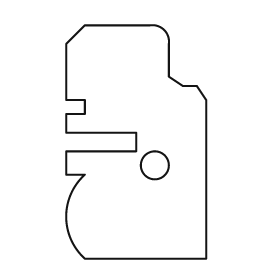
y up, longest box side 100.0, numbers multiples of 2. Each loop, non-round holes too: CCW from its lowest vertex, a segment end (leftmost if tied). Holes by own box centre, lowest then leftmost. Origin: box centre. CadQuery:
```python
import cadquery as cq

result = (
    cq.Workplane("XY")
    .moveTo(-22.0, -50.0)
    .lineTo(30.0, -50.0)
    .lineTo(30.0, 18.0)
    .lineTo(26.0, 24.0)
    .lineTo(20.0, 24.0)
    .lineTo(14.0, 28.0)
    .lineTo(14.0, 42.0)
    .threePointArc((12.0, 48.0), (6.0, 50.0))
    .lineTo(-22.0, 50.0)
    .lineTo(-30.0, 42.0)
    .lineTo(-30.0, 18.0)
    .lineTo(-22.0, 18.0)
    .lineTo(-22.0, 12.0)
    .lineTo(-30.0, 12.0)
    .lineTo(-30.0, 4.0)
    .lineTo(0.0, 4.0)
    .lineTo(0.0, -4.0)
    .lineTo(-30.0, -4.0)
    .lineTo(-30.0, -14.0)
    .lineTo(-22.0, -14.0)
    .threePointArc((-30.0, -32.0), (-22.0, -50.0))
    .close()
    .moveTo(8.0, -10.0)
    .circle(6.0)
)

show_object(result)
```